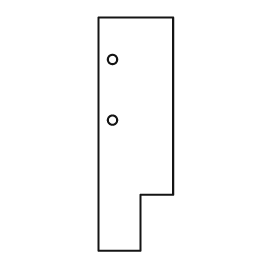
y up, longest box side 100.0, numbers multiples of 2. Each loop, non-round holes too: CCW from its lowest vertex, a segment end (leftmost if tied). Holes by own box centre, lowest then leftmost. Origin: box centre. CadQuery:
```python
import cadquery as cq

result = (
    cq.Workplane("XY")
    .moveTo(-16.0, -50.0)
    .lineTo(2.0, -50.0)
    .lineTo(2.0, -26.0)
    .lineTo(16.0, -26.0)
    .lineTo(16.0, 50.0)
    .lineTo(-16.0, 50.0)
    .close()
    .moveTo(-10.0, 6.0)
    .circle(2.0)
    .moveTo(-10.0, 32.0)
    .circle(2.0)
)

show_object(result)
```